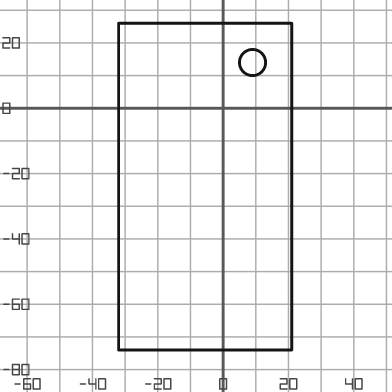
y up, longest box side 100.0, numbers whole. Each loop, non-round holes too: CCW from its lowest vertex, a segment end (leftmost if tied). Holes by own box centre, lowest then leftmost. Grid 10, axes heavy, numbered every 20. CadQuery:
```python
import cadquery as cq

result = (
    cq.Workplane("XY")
    .moveTo(-32.0, -74.0)
    .lineTo(21.0, -74.0)
    .lineTo(21.0, 26.0)
    .lineTo(-32.0, 26.0)
    .close()
    .moveTo(9.0, 14.0)
    .circle(4.0)
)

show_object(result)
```